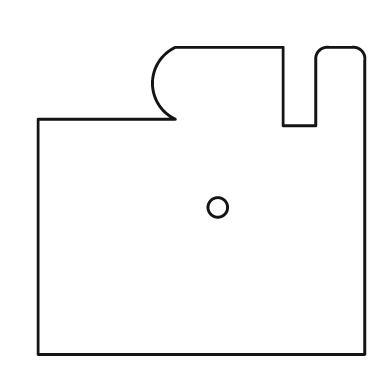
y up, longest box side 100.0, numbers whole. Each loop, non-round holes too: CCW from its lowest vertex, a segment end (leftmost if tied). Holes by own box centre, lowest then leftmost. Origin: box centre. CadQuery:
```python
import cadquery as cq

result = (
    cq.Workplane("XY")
    .moveTo(-50.0, -47.0)
    .lineTo(50.0, -47.0)
    .lineTo(50.0, 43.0)
    .threePointArc((49.0, 46.0), (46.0, 47.0))
    .lineTo(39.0, 47.0)
    .threePointArc((36.0, 46.0), (35.0, 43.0))
    .lineTo(35.0, 23.0)
    .lineTo(25.0, 23.0)
    .lineTo(25.0, 47.0)
    .lineTo(-8.0, 47.0)
    .threePointArc((-15.0, 36.0), (-8.0, 25.0))
    .lineTo(-50.0, 25.0)
    .close()
    .moveTo(5.0, -2.0)
    .circle(3.0)
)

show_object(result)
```